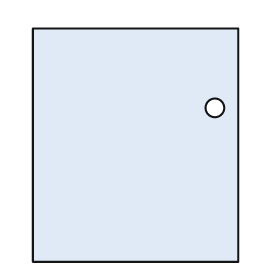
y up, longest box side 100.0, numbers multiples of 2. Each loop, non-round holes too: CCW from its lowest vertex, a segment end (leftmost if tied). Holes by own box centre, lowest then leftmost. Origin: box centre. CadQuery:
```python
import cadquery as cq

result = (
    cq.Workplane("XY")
    .moveTo(-44.0, -50.0)
    .lineTo(44.0, -50.0)
    .lineTo(44.0, 50.0)
    .lineTo(-44.0, 50.0)
    .close()
    .moveTo(34.0, 16.0)
    .circle(4.0)
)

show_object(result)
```